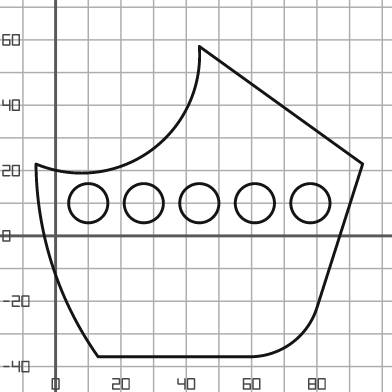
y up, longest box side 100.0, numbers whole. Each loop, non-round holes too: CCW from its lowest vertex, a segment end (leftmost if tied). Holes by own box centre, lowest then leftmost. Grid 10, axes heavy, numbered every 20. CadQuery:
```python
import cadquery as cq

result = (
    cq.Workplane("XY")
    .moveTo(13.0, -37.0)
    .lineTo(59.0, -37.0)
    .threePointArc((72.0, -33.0), (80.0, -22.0))
    .lineTo(94.0, 22.0)
    .lineTo(44.0, 58.0)
    .threePointArc((29.0, 26.0), (-6.0, 22.0))
    .threePointArc((-1.0, -9.0), (13.0, -37.0))
    .close()
    .moveTo(10.0, 10.0)
    .circle(6.0)
    .moveTo(27.0, 10.0)
    .circle(6.0)
    .moveTo(44.0, 10.0)
    .circle(6.0)
    .moveTo(61.0, 10.0)
    .circle(6.0)
    .moveTo(78.0, 10.0)
    .circle(6.0)
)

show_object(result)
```